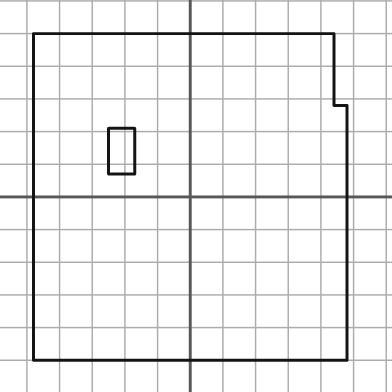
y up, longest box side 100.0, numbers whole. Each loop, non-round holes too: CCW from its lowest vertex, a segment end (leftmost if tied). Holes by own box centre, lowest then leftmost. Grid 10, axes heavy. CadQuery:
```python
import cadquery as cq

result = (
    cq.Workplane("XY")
    .moveTo(-48.0, -50.0)
    .lineTo(48.0, -50.0)
    .lineTo(48.0, 28.0)
    .lineTo(44.0, 28.0)
    .lineTo(44.0, 50.0)
    .lineTo(-48.0, 50.0)
    .close()
    .moveTo(-25.0, 7.0)
    .lineTo(-17.0, 7.0)
    .lineTo(-17.0, 21.0)
    .lineTo(-25.0, 21.0)
    .close()
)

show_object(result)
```